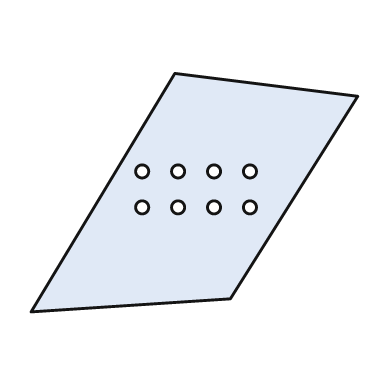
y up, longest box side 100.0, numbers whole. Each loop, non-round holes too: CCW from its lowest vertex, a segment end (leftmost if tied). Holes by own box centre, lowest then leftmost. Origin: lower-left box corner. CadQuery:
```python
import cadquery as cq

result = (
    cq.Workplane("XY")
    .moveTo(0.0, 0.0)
    .lineTo(61.0, 4.0)
    .lineTo(100.0, 66.0)
    .lineTo(44.0, 73.0)
    .close()
    .moveTo(34.0, 32.0)
    .circle(2.0)
    .moveTo(45.0, 32.0)
    .circle(2.0)
    .moveTo(56.0, 32.0)
    .circle(2.0)
    .moveTo(67.0, 32.0)
    .circle(2.0)
    .moveTo(34.0, 43.0)
    .circle(2.0)
    .moveTo(45.0, 43.0)
    .circle(2.0)
    .moveTo(56.0, 43.0)
    .circle(2.0)
    .moveTo(67.0, 43.0)
    .circle(2.0)
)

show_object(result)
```